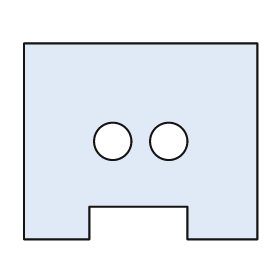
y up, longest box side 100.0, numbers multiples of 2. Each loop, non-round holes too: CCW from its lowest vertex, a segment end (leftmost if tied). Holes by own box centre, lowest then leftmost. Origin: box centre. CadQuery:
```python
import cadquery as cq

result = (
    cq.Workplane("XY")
    .moveTo(-50.0, -42.0)
    .lineTo(-22.0, -42.0)
    .lineTo(-22.0, -28.0)
    .lineTo(20.0, -28.0)
    .lineTo(20.0, -42.0)
    .lineTo(50.0, -42.0)
    .lineTo(50.0, 42.0)
    .lineTo(-50.0, 42.0)
    .close()
    .moveTo(-12.0, 0.0)
    .circle(8.0)
    .moveTo(12.0, 0.0)
    .circle(8.0)
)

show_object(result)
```